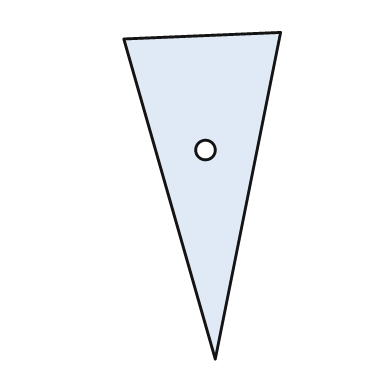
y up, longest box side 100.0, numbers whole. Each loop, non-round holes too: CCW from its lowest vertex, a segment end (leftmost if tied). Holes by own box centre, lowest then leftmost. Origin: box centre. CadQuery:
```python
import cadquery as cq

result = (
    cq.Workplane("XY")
    .moveTo(4.0, -50.0)
    .lineTo(24.0, 50.0)
    .lineTo(-24.0, 48.0)
    .close()
    .moveTo(1.0, 14.0)
    .circle(3.0)
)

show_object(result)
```